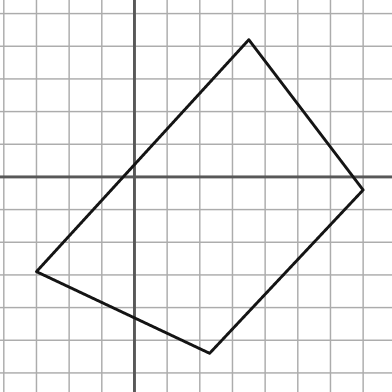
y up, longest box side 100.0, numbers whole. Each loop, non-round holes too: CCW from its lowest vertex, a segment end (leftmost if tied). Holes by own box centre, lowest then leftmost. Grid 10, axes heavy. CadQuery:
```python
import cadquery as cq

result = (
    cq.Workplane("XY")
    .moveTo(23.0, -54.0)
    .lineTo(70.0, -4.0)
    .lineTo(35.0, 42.0)
    .lineTo(-30.0, -29.0)
    .close()
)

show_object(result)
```